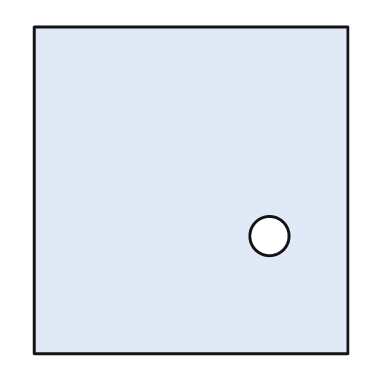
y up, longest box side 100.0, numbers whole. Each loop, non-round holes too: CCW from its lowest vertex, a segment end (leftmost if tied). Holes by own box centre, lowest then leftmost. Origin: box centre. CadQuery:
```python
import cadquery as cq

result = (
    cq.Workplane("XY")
    .moveTo(-48.0, -50.0)
    .lineTo(48.0, -50.0)
    .lineTo(48.0, 50.0)
    .lineTo(-48.0, 50.0)
    .close()
    .moveTo(24.0, -14.0)
    .circle(6.0)
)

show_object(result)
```